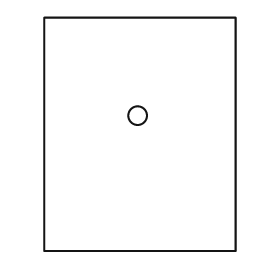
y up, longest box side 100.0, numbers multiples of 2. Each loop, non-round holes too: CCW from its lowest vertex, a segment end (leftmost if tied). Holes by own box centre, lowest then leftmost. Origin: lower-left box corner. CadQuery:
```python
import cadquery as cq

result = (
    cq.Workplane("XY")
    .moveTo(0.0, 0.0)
    .lineTo(82.0, 0.0)
    .lineTo(82.0, 100.0)
    .lineTo(0.0, 100.0)
    .close()
    .moveTo(40.0, 58.0)
    .circle(4.0)
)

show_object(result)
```